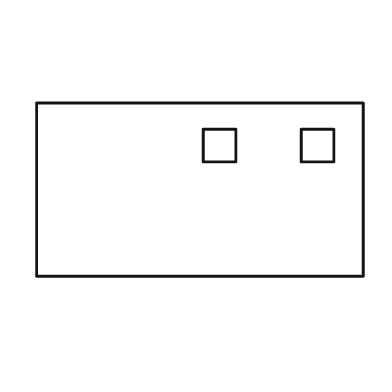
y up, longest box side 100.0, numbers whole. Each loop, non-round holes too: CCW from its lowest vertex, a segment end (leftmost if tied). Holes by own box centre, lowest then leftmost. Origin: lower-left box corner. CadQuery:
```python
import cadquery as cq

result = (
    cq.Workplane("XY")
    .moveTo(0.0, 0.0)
    .lineTo(100.0, 0.0)
    .lineTo(100.0, 53.0)
    .lineTo(0.0, 53.0)
    .close()
    .moveTo(51.0, 35.0)
    .lineTo(61.0, 35.0)
    .lineTo(61.0, 45.0)
    .lineTo(51.0, 45.0)
    .close()
    .moveTo(81.0, 35.0)
    .lineTo(91.0, 35.0)
    .lineTo(91.0, 45.0)
    .lineTo(81.0, 45.0)
    .close()
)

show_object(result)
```